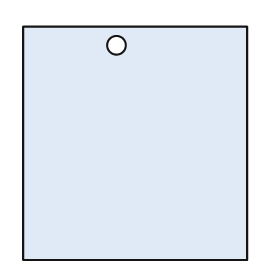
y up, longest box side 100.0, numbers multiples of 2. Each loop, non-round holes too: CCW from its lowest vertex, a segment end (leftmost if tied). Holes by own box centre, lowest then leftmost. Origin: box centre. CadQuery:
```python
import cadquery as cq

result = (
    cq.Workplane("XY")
    .moveTo(-48.0, -50.0)
    .lineTo(48.0, -50.0)
    .lineTo(48.0, 50.0)
    .lineTo(-48.0, 50.0)
    .close()
    .moveTo(-8.0, 42.0)
    .circle(4.0)
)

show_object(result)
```